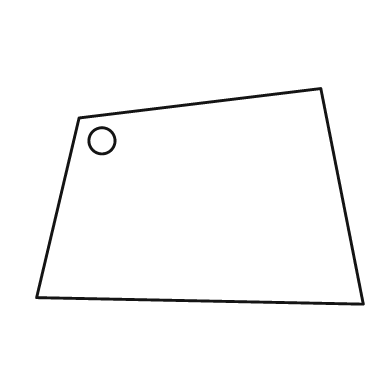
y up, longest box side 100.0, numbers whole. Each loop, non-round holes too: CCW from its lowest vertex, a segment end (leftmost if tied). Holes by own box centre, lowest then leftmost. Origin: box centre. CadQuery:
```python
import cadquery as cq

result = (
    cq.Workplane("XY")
    .moveTo(50.0, -33.0)
    .lineTo(37.0, 33.0)
    .lineTo(-37.0, 24.0)
    .lineTo(-50.0, -31.0)
    .close()
    .moveTo(-30.0, 17.0)
    .circle(4.0)
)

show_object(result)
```